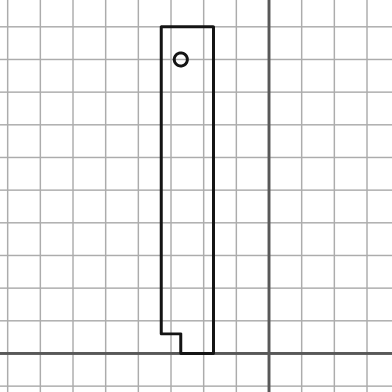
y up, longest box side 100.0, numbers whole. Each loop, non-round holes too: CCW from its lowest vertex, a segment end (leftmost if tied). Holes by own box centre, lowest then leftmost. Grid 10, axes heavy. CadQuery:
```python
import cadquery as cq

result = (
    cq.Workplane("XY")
    .moveTo(-27.0, 0.0)
    .lineTo(-17.0, 0.0)
    .lineTo(-17.0, 100.0)
    .lineTo(-33.0, 100.0)
    .lineTo(-33.0, 6.0)
    .lineTo(-27.0, 6.0)
    .close()
    .moveTo(-27.0, 90.0)
    .circle(2.0)
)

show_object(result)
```